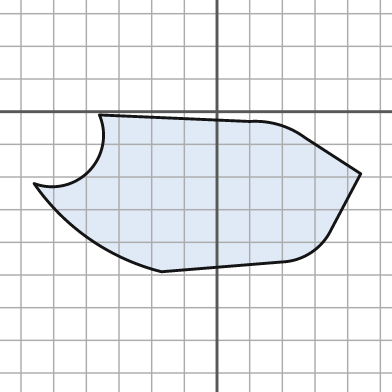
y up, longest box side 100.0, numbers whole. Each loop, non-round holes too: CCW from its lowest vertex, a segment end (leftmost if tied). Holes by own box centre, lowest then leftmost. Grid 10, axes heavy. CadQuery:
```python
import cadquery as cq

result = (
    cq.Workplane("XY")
    .moveTo(-17.0, -49.0)
    .lineTo(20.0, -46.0)
    .threePointArc((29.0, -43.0), (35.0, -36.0))
    .lineTo(44.0, -19.0)
    .lineTo(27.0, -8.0)
    .threePointArc((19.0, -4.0), (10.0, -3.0))
    .lineTo(-36.0, -1.0)
    .threePointArc((-39.0, -18.0), (-56.0, -22.0))
    .threePointArc((-39.0, -39.0), (-17.0, -49.0))
    .close()
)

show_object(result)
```